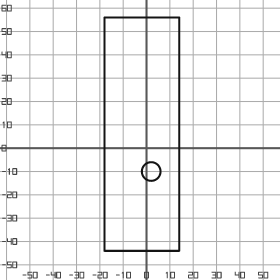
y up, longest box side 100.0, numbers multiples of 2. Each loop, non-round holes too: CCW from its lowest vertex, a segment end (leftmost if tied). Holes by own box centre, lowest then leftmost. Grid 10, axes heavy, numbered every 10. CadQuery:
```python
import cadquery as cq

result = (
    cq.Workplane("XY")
    .moveTo(-18.0, -44.0)
    .lineTo(14.0, -44.0)
    .lineTo(14.0, 56.0)
    .lineTo(-18.0, 56.0)
    .close()
    .moveTo(2.0, -10.0)
    .circle(4.0)
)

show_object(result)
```